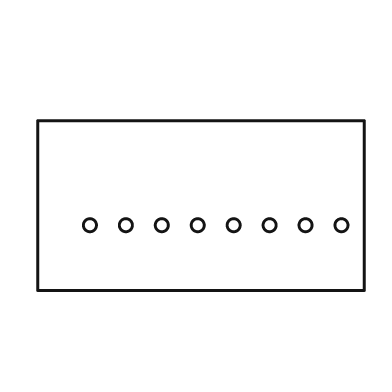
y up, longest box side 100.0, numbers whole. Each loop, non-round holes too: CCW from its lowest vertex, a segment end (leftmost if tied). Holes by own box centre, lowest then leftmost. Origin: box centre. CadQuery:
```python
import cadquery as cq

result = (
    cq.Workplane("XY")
    .moveTo(-50.0, -26.0)
    .lineTo(50.0, -26.0)
    .lineTo(50.0, 26.0)
    .lineTo(-50.0, 26.0)
    .close()
    .moveTo(-34.0, -6.0)
    .circle(2.0)
    .moveTo(-23.0, -6.0)
    .circle(2.0)
    .moveTo(-12.0, -6.0)
    .circle(2.0)
    .moveTo(-1.0, -6.0)
    .circle(2.0)
    .moveTo(10.0, -6.0)
    .circle(2.0)
    .moveTo(21.0, -6.0)
    .circle(2.0)
    .moveTo(32.0, -6.0)
    .circle(2.0)
    .moveTo(43.0, -6.0)
    .circle(2.0)
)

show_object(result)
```